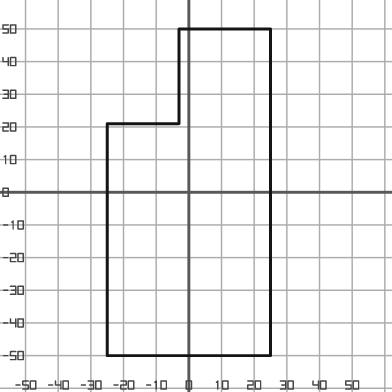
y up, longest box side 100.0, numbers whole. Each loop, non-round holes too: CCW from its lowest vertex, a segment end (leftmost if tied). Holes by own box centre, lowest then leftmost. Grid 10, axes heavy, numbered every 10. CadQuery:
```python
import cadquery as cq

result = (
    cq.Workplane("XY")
    .moveTo(-25.0, -50.0)
    .lineTo(25.0, -50.0)
    .lineTo(25.0, 50.0)
    .lineTo(-3.0, 50.0)
    .lineTo(-3.0, 21.0)
    .lineTo(-25.0, 21.0)
    .close()
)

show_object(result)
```